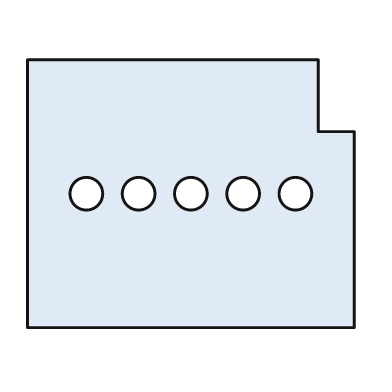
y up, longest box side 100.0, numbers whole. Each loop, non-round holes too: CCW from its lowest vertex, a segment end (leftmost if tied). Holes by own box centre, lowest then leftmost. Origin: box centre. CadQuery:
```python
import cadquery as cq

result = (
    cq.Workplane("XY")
    .moveTo(-50.0, -41.0)
    .lineTo(50.0, -41.0)
    .lineTo(50.0, 19.0)
    .lineTo(39.0, 19.0)
    .lineTo(39.0, 41.0)
    .lineTo(-50.0, 41.0)
    .close()
    .moveTo(-32.0, 0.0)
    .circle(5.0)
    .moveTo(-16.0, 0.0)
    .circle(5.0)
    .moveTo(0.0, 0.0)
    .circle(5.0)
    .moveTo(16.0, 0.0)
    .circle(5.0)
    .moveTo(32.0, 0.0)
    .circle(5.0)
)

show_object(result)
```